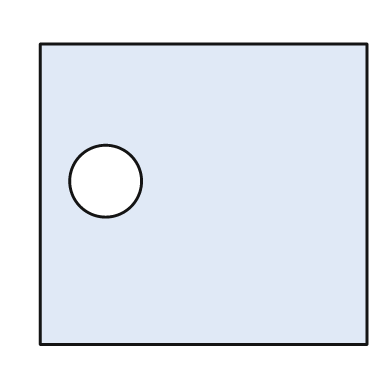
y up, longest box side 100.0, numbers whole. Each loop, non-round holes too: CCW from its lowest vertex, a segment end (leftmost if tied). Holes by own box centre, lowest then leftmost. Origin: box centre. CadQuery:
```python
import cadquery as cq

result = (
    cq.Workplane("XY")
    .moveTo(-50.0, -46.0)
    .lineTo(50.0, -46.0)
    .lineTo(50.0, 46.0)
    .lineTo(-50.0, 46.0)
    .close()
    .moveTo(-30.0, 4.0)
    .circle(11.0)
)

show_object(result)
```